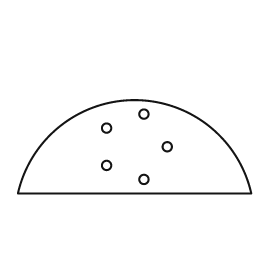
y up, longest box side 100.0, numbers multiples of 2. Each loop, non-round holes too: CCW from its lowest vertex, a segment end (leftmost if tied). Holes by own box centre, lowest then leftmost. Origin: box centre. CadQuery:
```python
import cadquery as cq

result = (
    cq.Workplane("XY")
    .moveTo(-50.0, -20.0)
    .lineTo(50.0, -20.0)
    .threePointArc((0.0, 20.0), (-50.0, -20.0))
    .close()
    .moveTo(4.0, -14.0)
    .circle(2.0)
    .moveTo(-12.0, -8.0)
    .circle(2.0)
    .moveTo(14.0, 0.0)
    .circle(2.0)
    .moveTo(-12.0, 8.0)
    .circle(2.0)
    .moveTo(4.0, 14.0)
    .circle(2.0)
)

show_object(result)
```